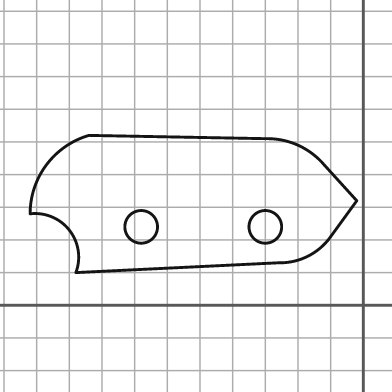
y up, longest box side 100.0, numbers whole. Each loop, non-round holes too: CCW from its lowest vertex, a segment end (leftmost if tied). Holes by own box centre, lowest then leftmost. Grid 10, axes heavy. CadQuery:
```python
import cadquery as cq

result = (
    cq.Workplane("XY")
    .moveTo(-88.0, 10.0)
    .lineTo(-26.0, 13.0)
    .threePointArc((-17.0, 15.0), (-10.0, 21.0))
    .lineTo(-2.0, 32.0)
    .lineTo(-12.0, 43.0)
    .threePointArc((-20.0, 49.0), (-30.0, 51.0))
    .lineTo(-84.0, 52.0)
    .threePointArc((-97.0, 43.0), (-102.0, 28.0))
    .threePointArc((-90.0, 23.0), (-88.0, 10.0))
    .close()
    .moveTo(-68.0, 24.0)
    .circle(5.0)
    .moveTo(-30.0, 24.0)
    .circle(5.0)
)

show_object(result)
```